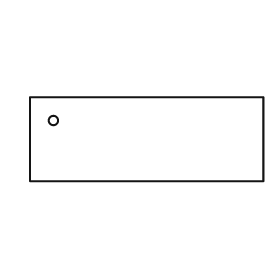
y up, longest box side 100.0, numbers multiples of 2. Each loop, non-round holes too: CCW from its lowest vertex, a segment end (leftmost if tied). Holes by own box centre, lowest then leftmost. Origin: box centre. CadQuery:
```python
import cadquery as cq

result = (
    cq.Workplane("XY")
    .moveTo(-50.0, -18.0)
    .lineTo(50.0, -18.0)
    .lineTo(50.0, 18.0)
    .lineTo(-50.0, 18.0)
    .close()
    .moveTo(-40.0, 8.0)
    .circle(2.0)
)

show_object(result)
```